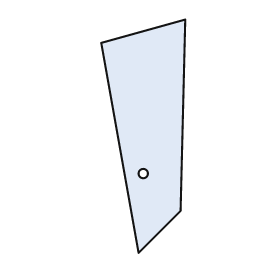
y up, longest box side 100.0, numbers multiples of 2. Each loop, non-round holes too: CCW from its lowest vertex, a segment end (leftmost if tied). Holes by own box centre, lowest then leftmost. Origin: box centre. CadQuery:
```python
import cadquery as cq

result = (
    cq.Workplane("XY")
    .moveTo(-2.0, -50.0)
    .lineTo(16.0, -32.0)
    .lineTo(18.0, 50.0)
    .lineTo(-18.0, 40.0)
    .close()
    .moveTo(0.0, -16.0)
    .circle(2.0)
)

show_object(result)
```